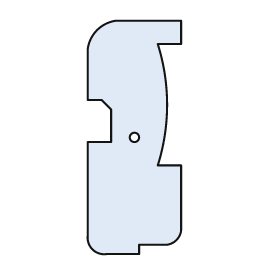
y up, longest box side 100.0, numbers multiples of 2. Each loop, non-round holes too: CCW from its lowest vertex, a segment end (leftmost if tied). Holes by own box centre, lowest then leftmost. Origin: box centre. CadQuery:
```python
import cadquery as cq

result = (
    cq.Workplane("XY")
    .moveTo(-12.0, -50.0)
    .lineTo(2.0, -50.0)
    .lineTo(2.0, -46.0)
    .lineTo(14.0, -46.0)
    .threePointArc((18.0, -44.0), (20.0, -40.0))
    .lineTo(20.0, -12.0)
    .lineTo(10.0, -12.0)
    .threePointArc((14.0, 14.0), (10.0, 40.0))
    .lineTo(20.0, 40.0)
    .lineTo(20.0, 50.0)
    .lineTo(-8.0, 50.0)
    .threePointArc((-16.0, 46.0), (-20.0, 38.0))
    .lineTo(-20.0, 16.0)
    .lineTo(-14.0, 16.0)
    .lineTo(-10.0, 12.0)
    .lineTo(-10.0, -2.0)
    .lineTo(-20.0, -2.0)
    .lineTo(-20.0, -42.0)
    .threePointArc((-18.0, -48.0), (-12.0, -50.0))
    .close()
    .moveTo(0.0, 0.0)
    .circle(2.0)
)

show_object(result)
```